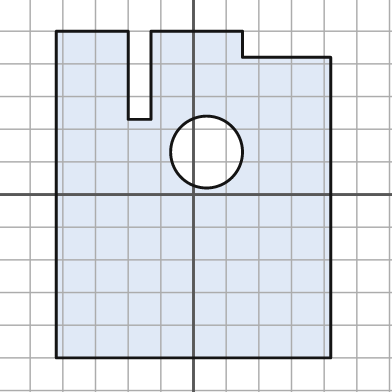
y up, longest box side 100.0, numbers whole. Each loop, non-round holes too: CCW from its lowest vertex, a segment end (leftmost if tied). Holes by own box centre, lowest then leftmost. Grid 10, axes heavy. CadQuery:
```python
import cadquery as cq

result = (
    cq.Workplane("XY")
    .moveTo(-42.0, -50.0)
    .lineTo(42.0, -50.0)
    .lineTo(42.0, 42.0)
    .lineTo(15.0, 42.0)
    .lineTo(15.0, 50.0)
    .lineTo(-13.0, 50.0)
    .lineTo(-13.0, 23.0)
    .lineTo(-20.0, 23.0)
    .lineTo(-20.0, 50.0)
    .lineTo(-42.0, 50.0)
    .close()
    .moveTo(4.0, 13.0)
    .circle(11.0)
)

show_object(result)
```